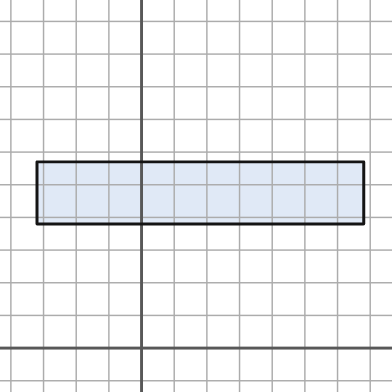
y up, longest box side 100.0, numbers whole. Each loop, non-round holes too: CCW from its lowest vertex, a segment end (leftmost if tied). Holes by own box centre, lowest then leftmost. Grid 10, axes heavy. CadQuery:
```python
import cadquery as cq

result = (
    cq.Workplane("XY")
    .moveTo(-32.0, 38.0)
    .lineTo(68.0, 38.0)
    .lineTo(68.0, 57.0)
    .lineTo(-32.0, 57.0)
    .close()
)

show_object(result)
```